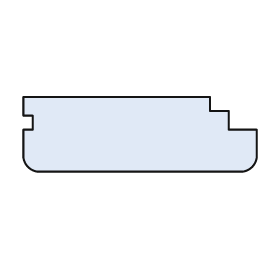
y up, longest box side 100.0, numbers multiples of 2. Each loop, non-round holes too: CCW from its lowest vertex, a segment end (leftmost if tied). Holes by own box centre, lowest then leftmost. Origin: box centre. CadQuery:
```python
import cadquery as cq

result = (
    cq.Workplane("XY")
    .moveTo(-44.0, -16.0)
    .lineTo(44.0, -16.0)
    .threePointArc((48.0, -14.0), (50.0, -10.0))
    .lineTo(50.0, 2.0)
    .lineTo(38.0, 2.0)
    .lineTo(38.0, 10.0)
    .lineTo(30.0, 10.0)
    .lineTo(30.0, 16.0)
    .lineTo(-50.0, 16.0)
    .lineTo(-50.0, 8.0)
    .lineTo(-46.0, 8.0)
    .lineTo(-46.0, 2.0)
    .lineTo(-50.0, 2.0)
    .lineTo(-50.0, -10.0)
    .threePointArc((-48.0, -14.0), (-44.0, -16.0))
    .close()
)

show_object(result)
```